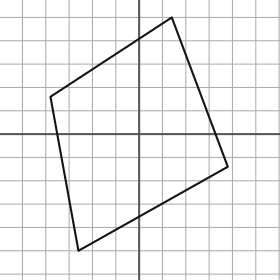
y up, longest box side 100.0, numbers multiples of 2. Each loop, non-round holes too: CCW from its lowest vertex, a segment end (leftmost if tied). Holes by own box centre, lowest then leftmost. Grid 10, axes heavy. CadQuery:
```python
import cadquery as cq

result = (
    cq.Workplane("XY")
    .moveTo(-26.0, -50.0)
    .lineTo(38.0, -14.0)
    .lineTo(14.0, 50.0)
    .lineTo(-38.0, 16.0)
    .close()
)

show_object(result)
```